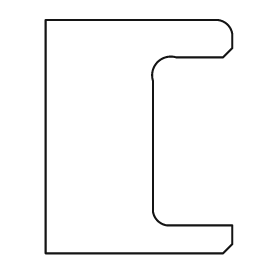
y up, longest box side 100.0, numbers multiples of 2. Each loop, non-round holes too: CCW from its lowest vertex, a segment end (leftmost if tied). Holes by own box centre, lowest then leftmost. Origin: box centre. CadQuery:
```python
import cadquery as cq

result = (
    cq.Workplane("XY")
    .moveTo(-40.0, -50.0)
    .lineTo(36.0, -50.0)
    .lineTo(40.0, -46.0)
    .lineTo(40.0, -38.0)
    .lineTo(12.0, -38.0)
    .threePointArc((8.0, -36.0), (6.0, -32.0))
    .lineTo(6.0, 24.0)
    .threePointArc((8.0, 32.0), (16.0, 34.0))
    .lineTo(36.0, 34.0)
    .lineTo(40.0, 38.0)
    .lineTo(40.0, 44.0)
    .threePointArc((38.0, 48.0), (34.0, 50.0))
    .lineTo(-40.0, 50.0)
    .close()
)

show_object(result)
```